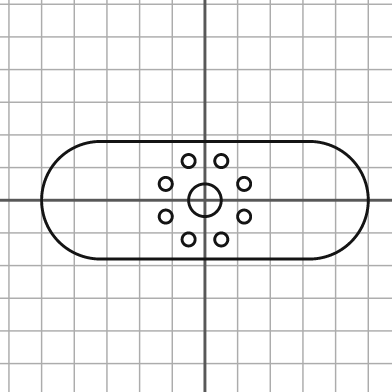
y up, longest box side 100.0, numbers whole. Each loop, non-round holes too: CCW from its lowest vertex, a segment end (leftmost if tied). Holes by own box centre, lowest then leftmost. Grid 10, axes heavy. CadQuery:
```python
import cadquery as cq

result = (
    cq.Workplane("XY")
    .moveTo(-32.0, -18.0)
    .lineTo(32.0, -18.0)
    .threePointArc((50.0, 0.0), (32.0, 18.0))
    .lineTo(-32.0, 18.0)
    .threePointArc((-50.0, 0.0), (-32.0, -18.0))
    .close()
    .moveTo(-5.0, -12.0)
    .circle(2.0)
    .moveTo(5.0, -12.0)
    .circle(2.0)
    .moveTo(-12.0, -5.0)
    .circle(2.0)
    .moveTo(12.0, -5.0)
    .circle(2.0)
    .moveTo(0.0, 0.0)
    .circle(5.0)
    .moveTo(-12.0, 5.0)
    .circle(2.0)
    .moveTo(12.0, 5.0)
    .circle(2.0)
    .moveTo(-5.0, 12.0)
    .circle(2.0)
    .moveTo(5.0, 12.0)
    .circle(2.0)
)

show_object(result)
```